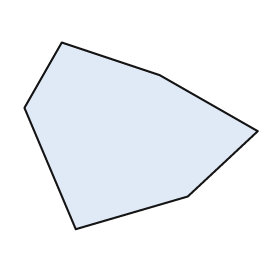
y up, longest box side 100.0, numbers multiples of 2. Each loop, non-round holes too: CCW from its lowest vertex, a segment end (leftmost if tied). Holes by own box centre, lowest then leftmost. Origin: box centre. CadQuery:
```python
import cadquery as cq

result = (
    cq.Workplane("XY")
    .moveTo(-28.0, -40.0)
    .lineTo(20.0, -26.0)
    .lineTo(50.0, 2.0)
    .lineTo(8.0, 26.0)
    .lineTo(-34.0, 40.0)
    .lineTo(-50.0, 12.0)
    .close()
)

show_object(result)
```